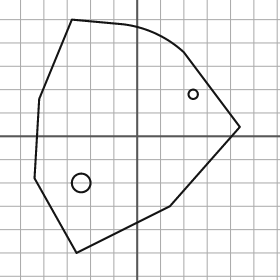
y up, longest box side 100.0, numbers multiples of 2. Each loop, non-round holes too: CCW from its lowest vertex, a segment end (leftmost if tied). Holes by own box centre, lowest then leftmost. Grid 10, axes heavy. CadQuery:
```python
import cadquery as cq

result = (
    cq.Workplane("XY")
    .moveTo(-26.0, -50.0)
    .lineTo(14.0, -30.0)
    .lineTo(44.0, 4.0)
    .lineTo(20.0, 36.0)
    .threePointArc((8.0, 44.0), (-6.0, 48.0))
    .lineTo(-28.0, 50.0)
    .lineTo(-42.0, 16.0)
    .lineTo(-44.0, -18.0)
    .close()
    .moveTo(-24.0, -20.0)
    .circle(4.0)
    .moveTo(24.0, 18.0)
    .circle(2.0)
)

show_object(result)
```